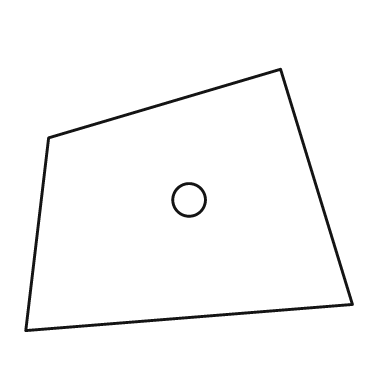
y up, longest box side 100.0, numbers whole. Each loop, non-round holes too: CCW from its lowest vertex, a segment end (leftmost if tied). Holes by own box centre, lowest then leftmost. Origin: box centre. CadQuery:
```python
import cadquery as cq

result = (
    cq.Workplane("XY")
    .moveTo(-50.0, -40.0)
    .lineTo(50.0, -32.0)
    .lineTo(28.0, 40.0)
    .lineTo(-43.0, 19.0)
    .close()
    .moveTo(0.0, 0.0)
    .circle(5.0)
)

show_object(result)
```